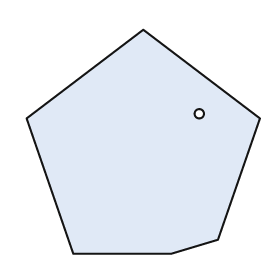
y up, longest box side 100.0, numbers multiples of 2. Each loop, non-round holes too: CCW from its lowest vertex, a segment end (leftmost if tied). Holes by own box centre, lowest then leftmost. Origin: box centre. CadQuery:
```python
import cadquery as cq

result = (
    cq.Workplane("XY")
    .moveTo(-30.0, -48.0)
    .lineTo(12.0, -48.0)
    .lineTo(32.0, -42.0)
    .lineTo(50.0, 10.0)
    .lineTo(0.0, 48.0)
    .lineTo(-50.0, 10.0)
    .close()
    .moveTo(24.0, 12.0)
    .circle(2.0)
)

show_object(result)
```